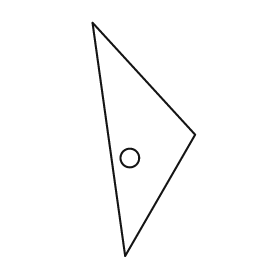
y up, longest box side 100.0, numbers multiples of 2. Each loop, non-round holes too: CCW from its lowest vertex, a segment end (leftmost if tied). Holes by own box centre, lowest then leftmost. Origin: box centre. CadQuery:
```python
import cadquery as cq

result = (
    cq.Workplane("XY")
    .moveTo(-8.0, -50.0)
    .lineTo(22.0, 2.0)
    .lineTo(-22.0, 50.0)
    .close()
    .moveTo(-6.0, -8.0)
    .circle(4.0)
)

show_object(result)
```